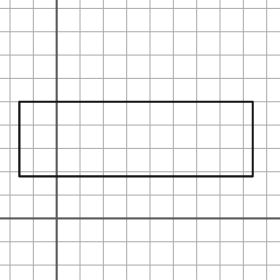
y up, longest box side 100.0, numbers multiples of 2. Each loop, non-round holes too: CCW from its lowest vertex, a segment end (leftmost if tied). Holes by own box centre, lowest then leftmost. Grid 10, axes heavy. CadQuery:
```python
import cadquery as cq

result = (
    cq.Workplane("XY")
    .moveTo(-16.0, 18.0)
    .lineTo(84.0, 18.0)
    .lineTo(84.0, 50.0)
    .lineTo(-16.0, 50.0)
    .close()
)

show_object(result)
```